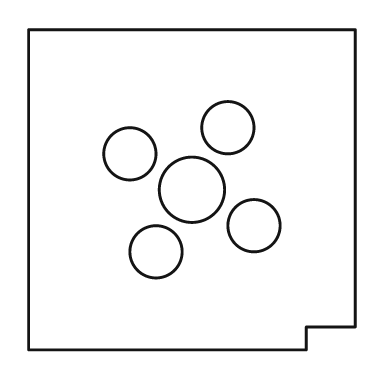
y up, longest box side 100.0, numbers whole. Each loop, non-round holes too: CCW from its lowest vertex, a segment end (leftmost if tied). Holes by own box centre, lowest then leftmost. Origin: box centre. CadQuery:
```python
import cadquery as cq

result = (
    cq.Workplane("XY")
    .moveTo(-50.0, -49.0)
    .lineTo(35.0, -49.0)
    .lineTo(35.0, -42.0)
    .lineTo(50.0, -42.0)
    .lineTo(50.0, 49.0)
    .lineTo(-50.0, 49.0)
    .close()
    .moveTo(-11.0, -19.0)
    .circle(8.0)
    .moveTo(19.0, -11.0)
    .circle(8.0)
    .moveTo(0.0, 0.0)
    .circle(10.0)
    .moveTo(-19.0, 11.0)
    .circle(8.0)
    .moveTo(11.0, 19.0)
    .circle(8.0)
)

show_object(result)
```